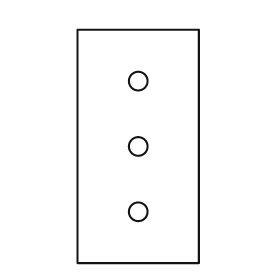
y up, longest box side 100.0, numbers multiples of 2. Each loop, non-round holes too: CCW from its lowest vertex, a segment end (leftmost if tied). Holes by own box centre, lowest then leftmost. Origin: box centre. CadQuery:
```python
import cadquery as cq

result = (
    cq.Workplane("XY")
    .moveTo(-26.0, -50.0)
    .lineTo(26.0, -50.0)
    .lineTo(26.0, 50.0)
    .lineTo(-26.0, 50.0)
    .close()
    .moveTo(0.0, -28.0)
    .circle(4.0)
    .moveTo(0.0, 0.0)
    .circle(4.0)
    .moveTo(0.0, 28.0)
    .circle(4.0)
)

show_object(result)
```